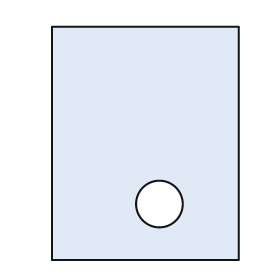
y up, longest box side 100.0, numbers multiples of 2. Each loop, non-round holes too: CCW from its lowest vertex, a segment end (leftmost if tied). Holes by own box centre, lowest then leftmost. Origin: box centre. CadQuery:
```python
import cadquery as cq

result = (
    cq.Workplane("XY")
    .moveTo(-40.0, -50.0)
    .lineTo(40.0, -50.0)
    .lineTo(40.0, 50.0)
    .lineTo(-40.0, 50.0)
    .close()
    .moveTo(6.0, -26.0)
    .circle(10.0)
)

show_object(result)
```